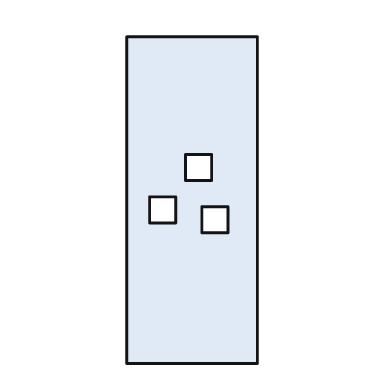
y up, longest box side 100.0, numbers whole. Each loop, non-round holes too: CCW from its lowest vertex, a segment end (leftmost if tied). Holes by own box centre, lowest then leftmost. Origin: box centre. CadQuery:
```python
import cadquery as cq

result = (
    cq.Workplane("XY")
    .moveTo(-20.0, -50.0)
    .lineTo(20.0, -50.0)
    .lineTo(20.0, 50.0)
    .lineTo(-20.0, 50.0)
    .close()
    .moveTo(3.0, -10.0)
    .lineTo(11.0, -10.0)
    .lineTo(11.0, -2.0)
    .lineTo(3.0, -2.0)
    .close()
    .moveTo(-13.0, -7.0)
    .lineTo(-5.0, -7.0)
    .lineTo(-5.0, 1.0)
    .lineTo(-13.0, 1.0)
    .close()
    .moveTo(-2.0, 6.0)
    .lineTo(6.0, 6.0)
    .lineTo(6.0, 14.0)
    .lineTo(-2.0, 14.0)
    .close()
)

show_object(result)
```